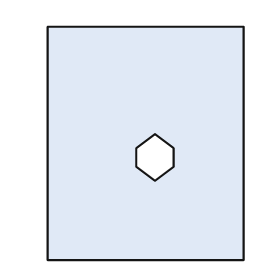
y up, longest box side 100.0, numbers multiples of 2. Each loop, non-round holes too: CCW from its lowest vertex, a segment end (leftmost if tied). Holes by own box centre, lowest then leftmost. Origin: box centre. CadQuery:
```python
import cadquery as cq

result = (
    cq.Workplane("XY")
    .moveTo(-42.0, -50.0)
    .lineTo(42.0, -50.0)
    .lineTo(42.0, 50.0)
    .lineTo(-42.0, 50.0)
    .close()
    .moveTo(4.0, -16.0)
    .lineTo(12.0, -10.0)
    .lineTo(12.0, -2.0)
    .lineTo(4.0, 4.0)
    .lineTo(-4.0, -2.0)
    .lineTo(-4.0, -10.0)
    .close()
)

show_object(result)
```